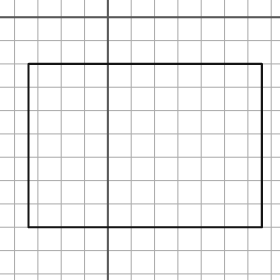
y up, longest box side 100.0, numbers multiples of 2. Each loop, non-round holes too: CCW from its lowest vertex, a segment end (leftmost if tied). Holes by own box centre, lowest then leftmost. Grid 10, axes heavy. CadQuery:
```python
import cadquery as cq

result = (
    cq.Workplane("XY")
    .moveTo(-34.0, -90.0)
    .lineTo(66.0, -90.0)
    .lineTo(66.0, -20.0)
    .lineTo(-34.0, -20.0)
    .close()
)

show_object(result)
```